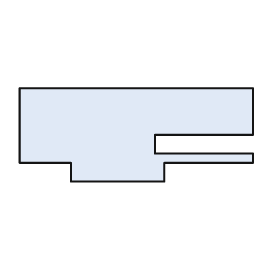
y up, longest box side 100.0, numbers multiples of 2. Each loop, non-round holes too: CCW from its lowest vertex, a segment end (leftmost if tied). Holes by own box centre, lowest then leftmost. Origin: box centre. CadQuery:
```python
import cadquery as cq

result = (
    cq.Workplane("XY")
    .moveTo(-28.0, -20.0)
    .lineTo(12.0, -20.0)
    .lineTo(12.0, -12.0)
    .lineTo(50.0, -12.0)
    .lineTo(50.0, -8.0)
    .lineTo(8.0, -8.0)
    .lineTo(8.0, 0.0)
    .lineTo(50.0, 0.0)
    .lineTo(50.0, 20.0)
    .lineTo(-50.0, 20.0)
    .lineTo(-50.0, -12.0)
    .lineTo(-28.0, -12.0)
    .close()
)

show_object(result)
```